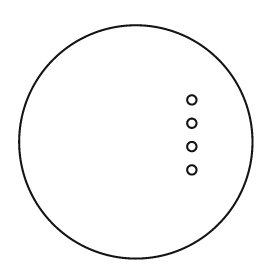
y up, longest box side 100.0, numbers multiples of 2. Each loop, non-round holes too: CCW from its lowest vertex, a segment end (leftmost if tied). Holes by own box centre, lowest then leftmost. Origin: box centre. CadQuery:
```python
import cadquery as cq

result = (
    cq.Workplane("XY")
    .moveTo(0.0, 0.0)
    .circle(50.0)
    .moveTo(24.0, -12.0)
    .circle(2.0)
    .moveTo(24.0, -2.0)
    .circle(2.0)
    .moveTo(24.0, 8.0)
    .circle(2.0)
    .moveTo(24.0, 18.0)
    .circle(2.0)
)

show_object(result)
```